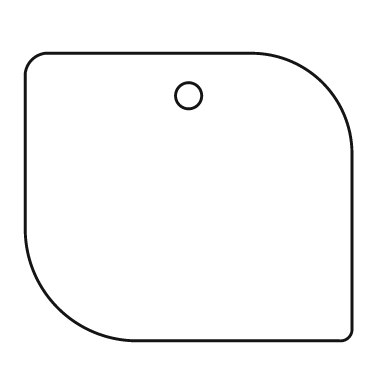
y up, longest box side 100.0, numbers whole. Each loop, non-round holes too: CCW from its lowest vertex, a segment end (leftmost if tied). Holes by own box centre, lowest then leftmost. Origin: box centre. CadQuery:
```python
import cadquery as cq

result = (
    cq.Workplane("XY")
    .moveTo(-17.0, -44.0)
    .lineTo(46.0, -44.0)
    .threePointArc((49.0, -43.0), (50.0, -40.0))
    .lineTo(50.0, 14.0)
    .threePointArc((41.0, 35.0), (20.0, 44.0))
    .lineTo(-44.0, 44.0)
    .threePointArc((-48.0, 42.0), (-50.0, 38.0))
    .lineTo(-50.0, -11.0)
    .threePointArc((-40.0, -34.0), (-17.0, -44.0))
    .close()
    .moveTo(0.0, 31.0)
    .circle(4.0)
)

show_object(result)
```